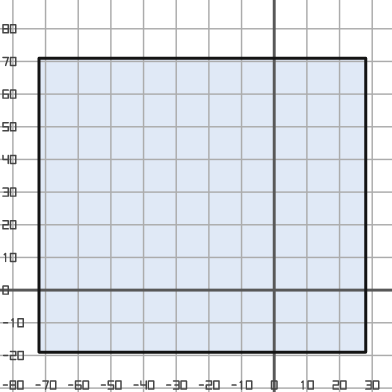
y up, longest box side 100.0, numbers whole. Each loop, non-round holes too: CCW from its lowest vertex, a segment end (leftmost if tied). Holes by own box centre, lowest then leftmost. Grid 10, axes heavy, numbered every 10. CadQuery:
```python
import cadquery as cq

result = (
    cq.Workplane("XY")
    .moveTo(-72.0, -19.0)
    .lineTo(28.0, -19.0)
    .lineTo(28.0, 71.0)
    .lineTo(-72.0, 71.0)
    .close()
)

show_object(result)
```